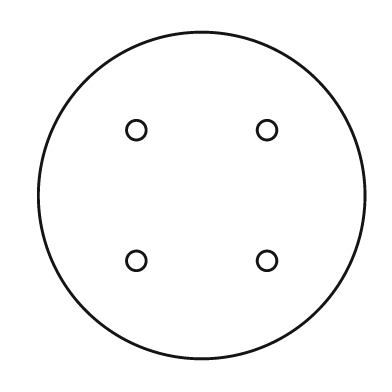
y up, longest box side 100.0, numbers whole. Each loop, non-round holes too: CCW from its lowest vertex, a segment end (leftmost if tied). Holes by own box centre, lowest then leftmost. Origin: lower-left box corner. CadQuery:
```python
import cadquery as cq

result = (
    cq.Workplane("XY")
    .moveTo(50.0, 50.0)
    .circle(50.0)
    .moveTo(30.0, 30.0)
    .circle(3.0)
    .moveTo(70.0, 30.0)
    .circle(3.0)
    .moveTo(30.0, 70.0)
    .circle(3.0)
    .moveTo(70.0, 70.0)
    .circle(3.0)
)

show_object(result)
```